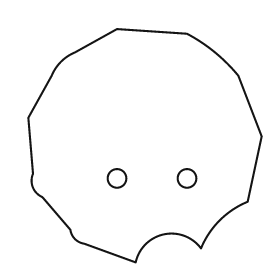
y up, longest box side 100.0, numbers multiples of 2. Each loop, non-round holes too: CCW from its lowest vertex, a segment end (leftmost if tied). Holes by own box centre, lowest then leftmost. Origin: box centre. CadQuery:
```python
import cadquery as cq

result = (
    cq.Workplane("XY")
    .moveTo(-4.0, -50.0)
    .threePointArc((8.0, -38.0), (24.0, -44.0))
    .threePointArc((32.0, -32.0), (44.0, -24.0))
    .lineTo(50.0, 4.0)
    .lineTo(40.0, 30.0)
    .threePointArc((30.0, 40.0), (18.0, 48.0))
    .lineTo(-12.0, 50.0)
    .lineTo(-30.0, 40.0)
    .threePointArc((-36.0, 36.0), (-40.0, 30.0))
    .lineTo(-50.0, 12.0)
    .lineTo(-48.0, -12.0)
    .threePointArc((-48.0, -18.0), (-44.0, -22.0))
    .lineTo(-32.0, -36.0)
    .threePointArc((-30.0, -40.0), (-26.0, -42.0))
    .close()
    .moveTo(-12.0, -14.0)
    .circle(4.0)
    .moveTo(18.0, -14.0)
    .circle(4.0)
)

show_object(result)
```